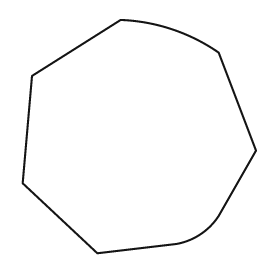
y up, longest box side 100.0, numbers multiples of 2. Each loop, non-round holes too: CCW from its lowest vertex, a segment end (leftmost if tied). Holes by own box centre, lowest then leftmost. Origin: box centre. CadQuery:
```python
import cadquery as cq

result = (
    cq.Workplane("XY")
    .moveTo(-18.0, -50.0)
    .lineTo(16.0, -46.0)
    .threePointArc((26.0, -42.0), (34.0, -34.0))
    .lineTo(50.0, -6.0)
    .lineTo(34.0, 36.0)
    .threePointArc((14.0, 46.0), (-8.0, 50.0))
    .lineTo(-46.0, 26.0)
    .lineTo(-50.0, -20.0)
    .close()
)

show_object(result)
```